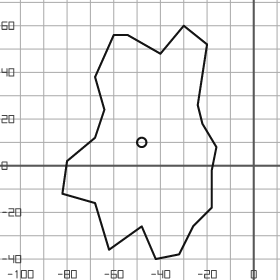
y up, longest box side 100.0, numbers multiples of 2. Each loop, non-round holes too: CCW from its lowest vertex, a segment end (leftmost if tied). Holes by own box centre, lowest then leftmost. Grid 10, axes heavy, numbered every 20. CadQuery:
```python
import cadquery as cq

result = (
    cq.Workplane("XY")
    .moveTo(-42.0, -40.0)
    .lineTo(-32.0, -38.0)
    .lineTo(-26.0, -26.0)
    .lineTo(-18.0, -18.0)
    .lineTo(-18.0, -2.0)
    .lineTo(-16.0, 8.0)
    .lineTo(-22.0, 18.0)
    .lineTo(-24.0, 26.0)
    .lineTo(-20.0, 52.0)
    .lineTo(-30.0, 60.0)
    .lineTo(-40.0, 48.0)
    .lineTo(-54.0, 56.0)
    .lineTo(-60.0, 56.0)
    .lineTo(-68.0, 38.0)
    .lineTo(-64.0, 24.0)
    .lineTo(-68.0, 12.0)
    .lineTo(-80.0, 2.0)
    .lineTo(-82.0, -12.0)
    .lineTo(-68.0, -16.0)
    .lineTo(-62.0, -36.0)
    .lineTo(-48.0, -26.0)
    .close()
    .moveTo(-48.0, 10.0)
    .circle(2.0)
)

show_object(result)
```